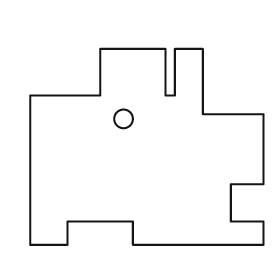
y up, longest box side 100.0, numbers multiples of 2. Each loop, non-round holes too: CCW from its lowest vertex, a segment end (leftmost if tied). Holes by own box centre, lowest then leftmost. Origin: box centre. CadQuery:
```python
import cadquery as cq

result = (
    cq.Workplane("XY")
    .moveTo(-50.0, -42.0)
    .lineTo(-34.0, -42.0)
    .lineTo(-34.0, -32.0)
    .lineTo(-6.0, -32.0)
    .lineTo(-6.0, -42.0)
    .lineTo(50.0, -42.0)
    .lineTo(50.0, -32.0)
    .lineTo(36.0, -32.0)
    .lineTo(36.0, -16.0)
    .lineTo(50.0, -16.0)
    .lineTo(50.0, 14.0)
    .lineTo(24.0, 14.0)
    .lineTo(24.0, 42.0)
    .lineTo(12.0, 42.0)
    .lineTo(12.0, 22.0)
    .lineTo(8.0, 22.0)
    .lineTo(8.0, 42.0)
    .lineTo(-20.0, 42.0)
    .lineTo(-20.0, 22.0)
    .lineTo(-50.0, 22.0)
    .close()
    .moveTo(-10.0, 12.0)
    .circle(4.0)
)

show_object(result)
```